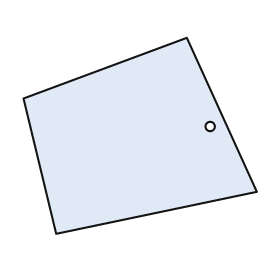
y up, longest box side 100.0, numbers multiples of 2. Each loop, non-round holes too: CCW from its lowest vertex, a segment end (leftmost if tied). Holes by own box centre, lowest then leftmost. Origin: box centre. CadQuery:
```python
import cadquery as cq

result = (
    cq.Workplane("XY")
    .moveTo(-36.0, -42.0)
    .lineTo(50.0, -24.0)
    .lineTo(20.0, 42.0)
    .lineTo(-50.0, 16.0)
    .close()
    .moveTo(30.0, 4.0)
    .circle(2.0)
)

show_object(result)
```